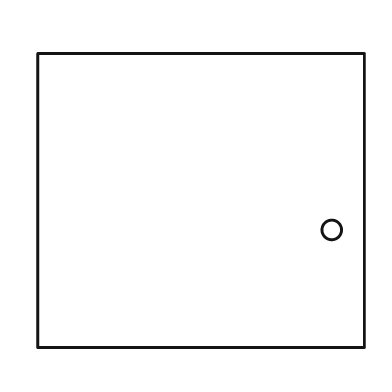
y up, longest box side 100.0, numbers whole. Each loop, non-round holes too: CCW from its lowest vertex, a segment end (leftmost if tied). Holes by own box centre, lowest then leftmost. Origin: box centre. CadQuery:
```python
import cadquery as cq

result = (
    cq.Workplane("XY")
    .moveTo(-50.0, -45.0)
    .lineTo(50.0, -45.0)
    .lineTo(50.0, 45.0)
    .lineTo(-50.0, 45.0)
    .close()
    .moveTo(40.0, -9.0)
    .circle(3.0)
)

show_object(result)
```